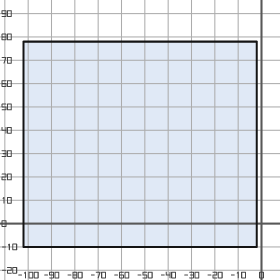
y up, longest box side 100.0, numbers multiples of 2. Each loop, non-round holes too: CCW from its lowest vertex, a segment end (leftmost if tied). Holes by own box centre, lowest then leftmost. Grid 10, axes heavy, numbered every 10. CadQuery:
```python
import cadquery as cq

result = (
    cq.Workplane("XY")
    .moveTo(-102.0, -10.0)
    .lineTo(-2.0, -10.0)
    .lineTo(-2.0, 78.0)
    .lineTo(-102.0, 78.0)
    .close()
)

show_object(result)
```